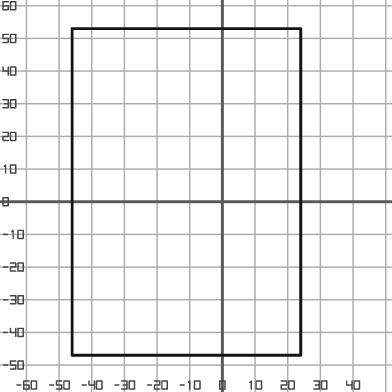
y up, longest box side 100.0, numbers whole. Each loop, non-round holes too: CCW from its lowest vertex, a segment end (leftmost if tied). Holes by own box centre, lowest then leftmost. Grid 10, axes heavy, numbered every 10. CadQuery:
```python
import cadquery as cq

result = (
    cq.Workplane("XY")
    .moveTo(-46.0, -47.0)
    .lineTo(24.0, -47.0)
    .lineTo(24.0, 53.0)
    .lineTo(-46.0, 53.0)
    .close()
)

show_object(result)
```